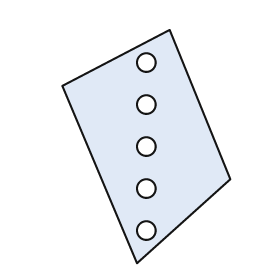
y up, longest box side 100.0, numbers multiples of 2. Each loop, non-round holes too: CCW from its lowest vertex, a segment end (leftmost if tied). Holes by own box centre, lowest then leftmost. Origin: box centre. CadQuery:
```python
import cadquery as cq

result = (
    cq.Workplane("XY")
    .moveTo(-4.0, -50.0)
    .lineTo(36.0, -14.0)
    .lineTo(10.0, 50.0)
    .lineTo(-36.0, 26.0)
    .close()
    .moveTo(0.0, -36.0)
    .circle(4.0)
    .moveTo(0.0, -18.0)
    .circle(4.0)
    .moveTo(0.0, 0.0)
    .circle(4.0)
    .moveTo(0.0, 18.0)
    .circle(4.0)
    .moveTo(0.0, 36.0)
    .circle(4.0)
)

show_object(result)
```